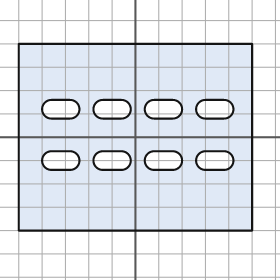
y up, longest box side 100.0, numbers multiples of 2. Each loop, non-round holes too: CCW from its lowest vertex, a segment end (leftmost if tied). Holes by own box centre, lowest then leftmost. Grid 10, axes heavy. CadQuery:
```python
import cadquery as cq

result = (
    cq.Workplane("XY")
    .moveTo(-50.0, -40.0)
    .lineTo(50.0, -40.0)
    .lineTo(50.0, 40.0)
    .lineTo(-50.0, 40.0)
    .close()
    .moveTo(-36.0, -14.0)
    .lineTo(-28.0, -14.0)
    .threePointArc((-24.0, -10.0), (-28.0, -6.0))
    .lineTo(-36.0, -6.0)
    .threePointArc((-40.0, -10.0), (-36.0, -14.0))
    .close()
    .moveTo(-14.0, -14.0)
    .lineTo(-6.0, -14.0)
    .threePointArc((-2.0, -10.0), (-6.0, -6.0))
    .lineTo(-14.0, -6.0)
    .threePointArc((-18.0, -10.0), (-14.0, -14.0))
    .close()
    .moveTo(8.0, -14.0)
    .lineTo(16.0, -14.0)
    .threePointArc((20.0, -10.0), (16.0, -6.0))
    .lineTo(8.0, -6.0)
    .threePointArc((4.0, -10.0), (8.0, -14.0))
    .close()
    .moveTo(30.0, -14.0)
    .lineTo(38.0, -14.0)
    .threePointArc((42.0, -10.0), (38.0, -6.0))
    .lineTo(30.0, -6.0)
    .threePointArc((26.0, -10.0), (30.0, -14.0))
    .close()
    .moveTo(-36.0, 8.0)
    .lineTo(-28.0, 8.0)
    .threePointArc((-24.0, 12.0), (-28.0, 16.0))
    .lineTo(-36.0, 16.0)
    .threePointArc((-40.0, 12.0), (-36.0, 8.0))
    .close()
    .moveTo(-14.0, 8.0)
    .lineTo(-6.0, 8.0)
    .threePointArc((-2.0, 12.0), (-6.0, 16.0))
    .lineTo(-14.0, 16.0)
    .threePointArc((-18.0, 12.0), (-14.0, 8.0))
    .close()
    .moveTo(8.0, 8.0)
    .lineTo(16.0, 8.0)
    .threePointArc((20.0, 12.0), (16.0, 16.0))
    .lineTo(8.0, 16.0)
    .threePointArc((4.0, 12.0), (8.0, 8.0))
    .close()
    .moveTo(30.0, 8.0)
    .lineTo(38.0, 8.0)
    .threePointArc((42.0, 12.0), (38.0, 16.0))
    .lineTo(30.0, 16.0)
    .threePointArc((26.0, 12.0), (30.0, 8.0))
    .close()
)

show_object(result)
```